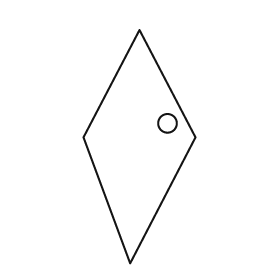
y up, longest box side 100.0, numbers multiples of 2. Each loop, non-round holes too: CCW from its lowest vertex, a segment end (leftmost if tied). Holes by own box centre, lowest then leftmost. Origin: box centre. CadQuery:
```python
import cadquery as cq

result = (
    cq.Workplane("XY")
    .moveTo(-4.0, -50.0)
    .lineTo(24.0, 4.0)
    .lineTo(0.0, 50.0)
    .lineTo(-24.0, 4.0)
    .close()
    .moveTo(12.0, 10.0)
    .circle(4.0)
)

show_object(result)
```